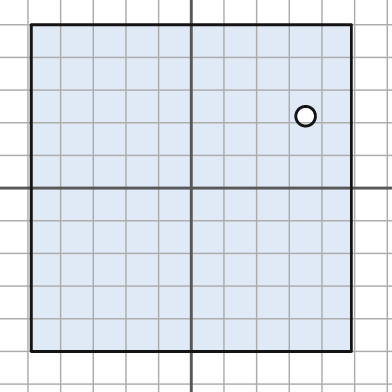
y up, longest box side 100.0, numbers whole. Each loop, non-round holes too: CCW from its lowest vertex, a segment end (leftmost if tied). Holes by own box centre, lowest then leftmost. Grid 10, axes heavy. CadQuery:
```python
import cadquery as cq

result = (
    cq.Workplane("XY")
    .moveTo(-49.0, -50.0)
    .lineTo(49.0, -50.0)
    .lineTo(49.0, 50.0)
    .lineTo(-49.0, 50.0)
    .close()
    .moveTo(35.0, 22.0)
    .circle(3.0)
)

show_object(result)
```